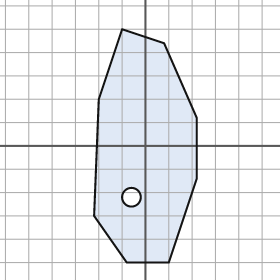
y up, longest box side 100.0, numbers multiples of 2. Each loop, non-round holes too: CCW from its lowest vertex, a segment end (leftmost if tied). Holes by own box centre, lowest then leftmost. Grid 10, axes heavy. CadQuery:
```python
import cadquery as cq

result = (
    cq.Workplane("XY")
    .moveTo(-8.0, -50.0)
    .lineTo(10.0, -50.0)
    .lineTo(22.0, -14.0)
    .lineTo(22.0, 12.0)
    .lineTo(8.0, 44.0)
    .lineTo(-10.0, 50.0)
    .lineTo(-20.0, 20.0)
    .lineTo(-22.0, -30.0)
    .close()
    .moveTo(-6.0, -22.0)
    .circle(4.0)
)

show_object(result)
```